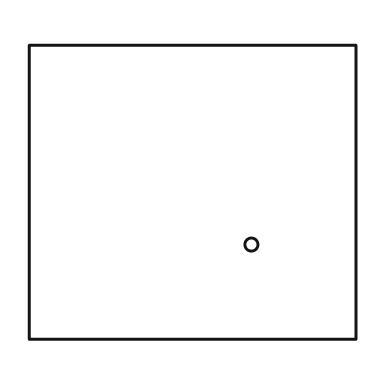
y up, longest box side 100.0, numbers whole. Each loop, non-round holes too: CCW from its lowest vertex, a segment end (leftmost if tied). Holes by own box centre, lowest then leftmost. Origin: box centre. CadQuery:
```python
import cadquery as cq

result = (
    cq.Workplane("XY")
    .moveTo(-50.0, -45.0)
    .lineTo(50.0, -45.0)
    .lineTo(50.0, 45.0)
    .lineTo(-50.0, 45.0)
    .close()
    .moveTo(18.0, -16.0)
    .circle(2.0)
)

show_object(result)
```